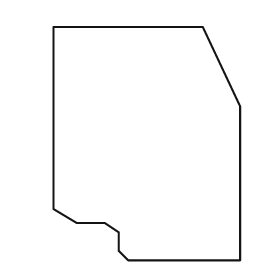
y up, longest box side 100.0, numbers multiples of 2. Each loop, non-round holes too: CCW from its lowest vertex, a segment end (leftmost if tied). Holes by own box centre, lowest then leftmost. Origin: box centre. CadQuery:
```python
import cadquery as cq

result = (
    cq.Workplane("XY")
    .moveTo(-8.0, -50.0)
    .lineTo(40.0, -50.0)
    .lineTo(40.0, 16.0)
    .lineTo(24.0, 50.0)
    .lineTo(-40.0, 50.0)
    .lineTo(-40.0, -28.0)
    .lineTo(-30.0, -34.0)
    .lineTo(-18.0, -34.0)
    .lineTo(-12.0, -38.0)
    .lineTo(-12.0, -46.0)
    .close()
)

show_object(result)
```